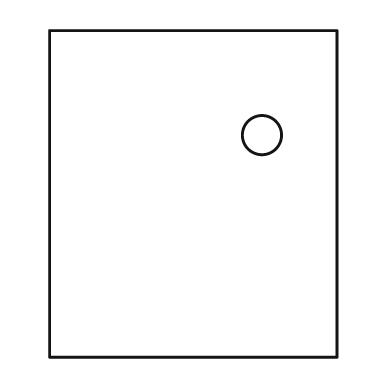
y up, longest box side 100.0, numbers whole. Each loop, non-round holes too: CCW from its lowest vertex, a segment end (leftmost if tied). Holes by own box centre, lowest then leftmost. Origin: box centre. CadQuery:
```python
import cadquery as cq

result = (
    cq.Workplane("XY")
    .moveTo(-44.0, -50.0)
    .lineTo(44.0, -50.0)
    .lineTo(44.0, 50.0)
    .lineTo(-44.0, 50.0)
    .close()
    .moveTo(21.0, 18.0)
    .circle(6.0)
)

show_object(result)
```